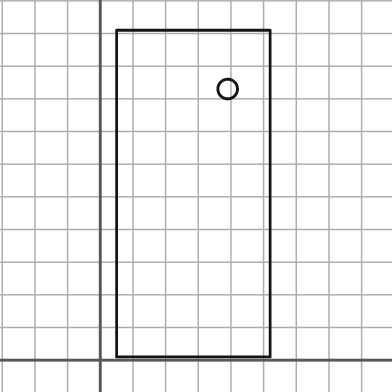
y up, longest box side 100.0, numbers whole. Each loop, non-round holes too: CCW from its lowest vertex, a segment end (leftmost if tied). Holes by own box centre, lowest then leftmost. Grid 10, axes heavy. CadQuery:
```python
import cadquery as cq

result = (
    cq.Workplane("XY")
    .moveTo(5.0, 1.0)
    .lineTo(52.0, 1.0)
    .lineTo(52.0, 101.0)
    .lineTo(5.0, 101.0)
    .close()
    .moveTo(39.0, 83.0)
    .circle(3.0)
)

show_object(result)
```